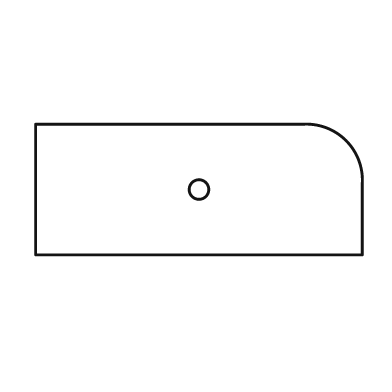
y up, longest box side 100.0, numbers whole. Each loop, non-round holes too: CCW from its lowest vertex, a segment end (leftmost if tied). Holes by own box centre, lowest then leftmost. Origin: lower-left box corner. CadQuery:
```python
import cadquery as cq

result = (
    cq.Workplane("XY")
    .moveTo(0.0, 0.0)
    .lineTo(100.0, 0.0)
    .lineTo(100.0, 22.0)
    .threePointArc((95.0, 35.0), (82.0, 40.0))
    .lineTo(0.0, 40.0)
    .close()
    .moveTo(50.0, 20.0)
    .circle(3.0)
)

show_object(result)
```